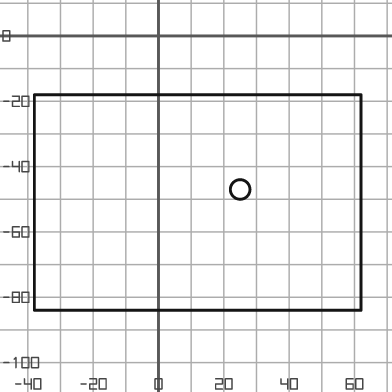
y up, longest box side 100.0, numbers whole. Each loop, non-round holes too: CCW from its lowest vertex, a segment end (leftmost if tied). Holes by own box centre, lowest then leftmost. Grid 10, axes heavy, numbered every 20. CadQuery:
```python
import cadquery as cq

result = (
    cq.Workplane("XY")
    .moveTo(-38.0, -84.0)
    .lineTo(62.0, -84.0)
    .lineTo(62.0, -18.0)
    .lineTo(-38.0, -18.0)
    .close()
    .moveTo(25.0, -47.0)
    .circle(3.0)
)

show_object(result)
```